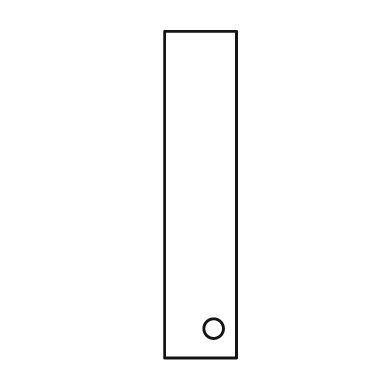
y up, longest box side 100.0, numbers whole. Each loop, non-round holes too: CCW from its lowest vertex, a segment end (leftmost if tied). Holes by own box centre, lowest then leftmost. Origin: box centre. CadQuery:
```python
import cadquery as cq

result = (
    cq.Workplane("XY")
    .moveTo(-11.0, -50.0)
    .lineTo(11.0, -50.0)
    .lineTo(11.0, 50.0)
    .lineTo(-11.0, 50.0)
    .close()
    .moveTo(4.0, -41.0)
    .circle(3.0)
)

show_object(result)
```